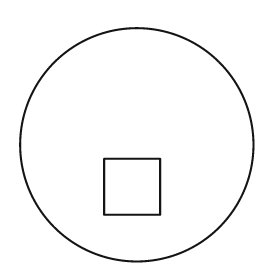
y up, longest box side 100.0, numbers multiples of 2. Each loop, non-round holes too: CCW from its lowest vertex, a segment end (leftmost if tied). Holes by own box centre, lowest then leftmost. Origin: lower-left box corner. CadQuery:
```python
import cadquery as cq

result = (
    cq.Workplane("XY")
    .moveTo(50.0, 50.0)
    .circle(50.0)
    .moveTo(36.0, 20.0)
    .lineTo(60.0, 20.0)
    .lineTo(60.0, 44.0)
    .lineTo(36.0, 44.0)
    .close()
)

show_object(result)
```